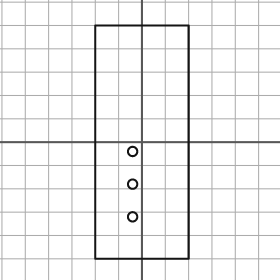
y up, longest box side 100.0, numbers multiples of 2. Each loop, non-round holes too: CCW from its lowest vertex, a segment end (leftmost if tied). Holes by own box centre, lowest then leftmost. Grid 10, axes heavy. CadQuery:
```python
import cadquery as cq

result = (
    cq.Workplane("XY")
    .moveTo(-20.0, -50.0)
    .lineTo(20.0, -50.0)
    .lineTo(20.0, 50.0)
    .lineTo(-20.0, 50.0)
    .close()
    .moveTo(-4.0, -32.0)
    .circle(2.0)
    .moveTo(-4.0, -18.0)
    .circle(2.0)
    .moveTo(-4.0, -4.0)
    .circle(2.0)
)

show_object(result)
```